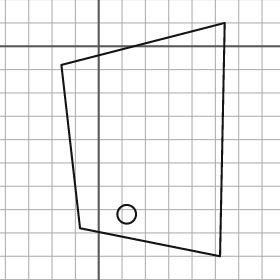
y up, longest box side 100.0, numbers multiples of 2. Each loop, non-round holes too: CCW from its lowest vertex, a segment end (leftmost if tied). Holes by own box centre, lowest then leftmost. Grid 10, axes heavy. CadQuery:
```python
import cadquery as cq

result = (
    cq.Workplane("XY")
    .moveTo(52.0, -90.0)
    .lineTo(54.0, 10.0)
    .lineTo(-16.0, -8.0)
    .lineTo(-8.0, -78.0)
    .close()
    .moveTo(12.0, -72.0)
    .circle(4.0)
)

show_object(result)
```